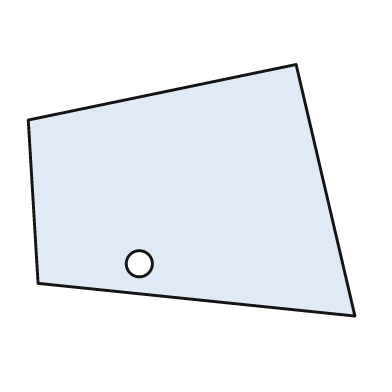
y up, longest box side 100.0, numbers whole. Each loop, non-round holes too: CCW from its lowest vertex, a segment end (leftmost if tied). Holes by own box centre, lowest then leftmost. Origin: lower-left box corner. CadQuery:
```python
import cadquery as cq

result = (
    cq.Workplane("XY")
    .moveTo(100.0, 0.0)
    .lineTo(82.0, 77.0)
    .lineTo(0.0, 60.0)
    .lineTo(3.0, 10.0)
    .close()
    .moveTo(34.0, 16.0)
    .circle(4.0)
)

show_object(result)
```